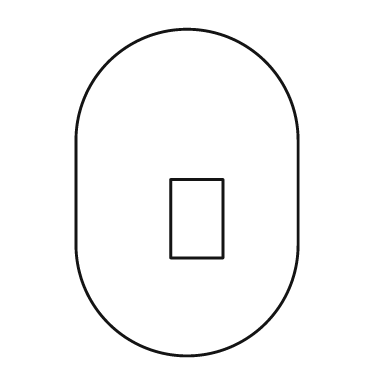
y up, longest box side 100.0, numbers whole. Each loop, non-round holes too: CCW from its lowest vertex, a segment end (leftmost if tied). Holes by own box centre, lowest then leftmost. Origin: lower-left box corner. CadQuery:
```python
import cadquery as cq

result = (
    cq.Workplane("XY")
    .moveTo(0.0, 34.0)
    .threePointArc((34.0, 0.0), (68.0, 34.0))
    .lineTo(68.0, 66.0)
    .threePointArc((34.0, 100.0), (0.0, 66.0))
    .close()
    .moveTo(29.0, 30.0)
    .lineTo(45.0, 30.0)
    .lineTo(45.0, 54.0)
    .lineTo(29.0, 54.0)
    .close()
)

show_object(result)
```